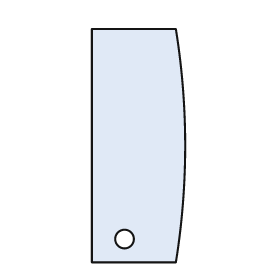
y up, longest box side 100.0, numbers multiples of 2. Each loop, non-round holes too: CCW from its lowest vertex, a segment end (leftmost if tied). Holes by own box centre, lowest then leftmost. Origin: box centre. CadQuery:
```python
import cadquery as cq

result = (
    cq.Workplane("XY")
    .moveTo(-20.0, -50.0)
    .lineTo(16.0, -50.0)
    .threePointArc((20.0, 0.0), (16.0, 50.0))
    .lineTo(-20.0, 50.0)
    .close()
    .moveTo(-6.0, -40.0)
    .circle(4.0)
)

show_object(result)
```